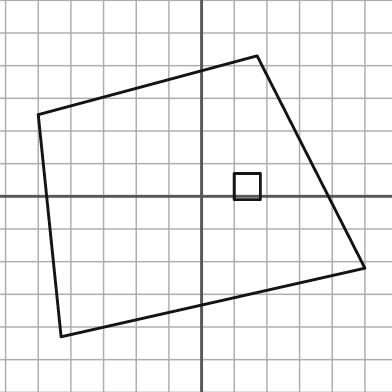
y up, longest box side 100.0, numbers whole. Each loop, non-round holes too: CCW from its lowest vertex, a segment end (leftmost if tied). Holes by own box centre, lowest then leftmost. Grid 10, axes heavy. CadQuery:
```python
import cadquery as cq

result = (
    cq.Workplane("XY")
    .moveTo(-43.0, -43.0)
    .lineTo(50.0, -22.0)
    .lineTo(17.0, 43.0)
    .lineTo(-50.0, 25.0)
    .close()
    .moveTo(10.0, -1.0)
    .lineTo(18.0, -1.0)
    .lineTo(18.0, 7.0)
    .lineTo(10.0, 7.0)
    .close()
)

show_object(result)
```